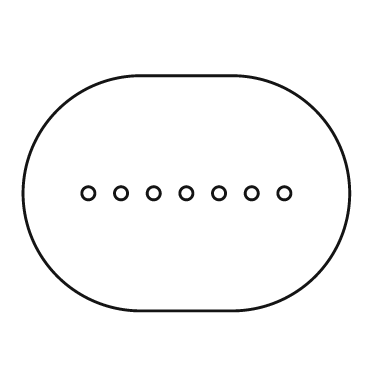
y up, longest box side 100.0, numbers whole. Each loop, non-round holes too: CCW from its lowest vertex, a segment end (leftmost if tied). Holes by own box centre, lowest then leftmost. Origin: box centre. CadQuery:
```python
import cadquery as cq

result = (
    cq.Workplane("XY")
    .moveTo(-14.0, -36.0)
    .lineTo(14.0, -36.0)
    .threePointArc((50.0, 0.0), (14.0, 36.0))
    .lineTo(-14.0, 36.0)
    .threePointArc((-50.0, 0.0), (-14.0, -36.0))
    .close()
    .moveTo(-30.0, 0.0)
    .circle(2.0)
    .moveTo(-20.0, 0.0)
    .circle(2.0)
    .moveTo(-10.0, 0.0)
    .circle(2.0)
    .moveTo(0.0, 0.0)
    .circle(2.0)
    .moveTo(10.0, 0.0)
    .circle(2.0)
    .moveTo(20.0, 0.0)
    .circle(2.0)
    .moveTo(30.0, 0.0)
    .circle(2.0)
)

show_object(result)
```